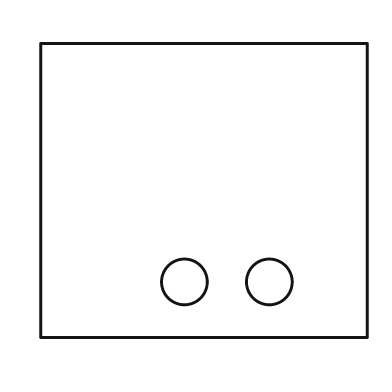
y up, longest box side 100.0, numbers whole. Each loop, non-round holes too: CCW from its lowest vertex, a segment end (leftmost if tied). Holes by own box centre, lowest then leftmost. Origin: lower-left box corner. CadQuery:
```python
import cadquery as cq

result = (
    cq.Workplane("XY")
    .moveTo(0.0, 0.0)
    .lineTo(100.0, 0.0)
    .lineTo(100.0, 90.0)
    .lineTo(0.0, 90.0)
    .close()
    .moveTo(44.0, 17.0)
    .circle(7.0)
    .moveTo(70.0, 17.0)
    .circle(7.0)
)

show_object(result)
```